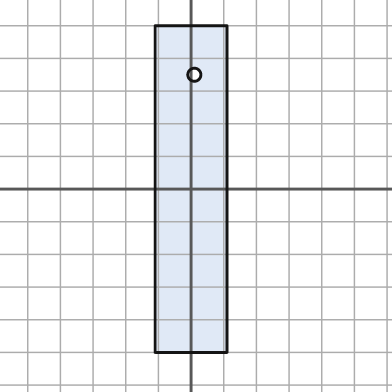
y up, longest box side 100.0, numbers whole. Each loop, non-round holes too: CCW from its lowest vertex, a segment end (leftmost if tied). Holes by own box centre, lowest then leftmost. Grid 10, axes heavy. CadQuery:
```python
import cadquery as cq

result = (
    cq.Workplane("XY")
    .moveTo(-11.0, -50.0)
    .lineTo(11.0, -50.0)
    .lineTo(11.0, 50.0)
    .lineTo(-11.0, 50.0)
    .close()
    .moveTo(1.0, 35.0)
    .circle(2.0)
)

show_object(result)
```